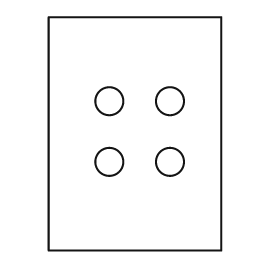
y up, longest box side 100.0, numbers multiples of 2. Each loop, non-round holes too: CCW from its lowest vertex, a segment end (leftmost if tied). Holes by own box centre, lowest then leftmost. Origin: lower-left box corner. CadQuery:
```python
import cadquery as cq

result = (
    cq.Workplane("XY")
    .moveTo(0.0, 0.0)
    .lineTo(74.0, 0.0)
    .lineTo(74.0, 100.0)
    .lineTo(0.0, 100.0)
    .close()
    .moveTo(26.0, 38.0)
    .circle(6.0)
    .moveTo(52.0, 38.0)
    .circle(6.0)
    .moveTo(26.0, 64.0)
    .circle(6.0)
    .moveTo(52.0, 64.0)
    .circle(6.0)
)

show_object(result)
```